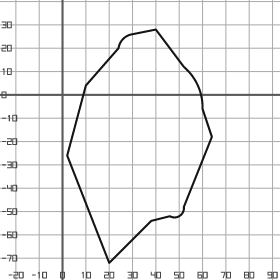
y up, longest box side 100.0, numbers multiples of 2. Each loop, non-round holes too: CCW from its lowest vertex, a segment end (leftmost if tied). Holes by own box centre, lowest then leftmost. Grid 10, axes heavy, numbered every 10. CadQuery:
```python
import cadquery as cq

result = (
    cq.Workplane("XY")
    .moveTo(20.0, -72.0)
    .lineTo(38.0, -54.0)
    .lineTo(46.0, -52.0)
    .threePointArc((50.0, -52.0), (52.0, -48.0))
    .lineTo(64.0, -18.0)
    .lineTo(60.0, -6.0)
    .threePointArc((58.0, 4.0), (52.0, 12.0))
    .lineTo(40.0, 28.0)
    .lineTo(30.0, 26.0)
    .threePointArc((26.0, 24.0), (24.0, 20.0))
    .lineTo(10.0, 4.0)
    .lineTo(2.0, -26.0)
    .close()
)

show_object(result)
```